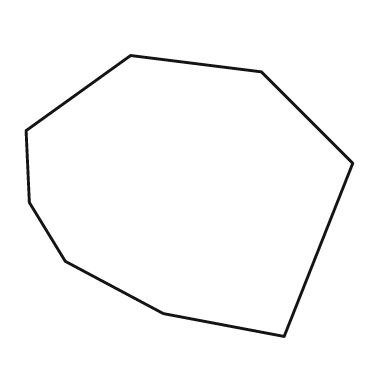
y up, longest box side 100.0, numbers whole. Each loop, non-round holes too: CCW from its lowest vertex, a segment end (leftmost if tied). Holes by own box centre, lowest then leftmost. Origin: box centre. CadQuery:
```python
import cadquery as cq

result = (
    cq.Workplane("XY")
    .moveTo(29.0, -43.0)
    .lineTo(50.0, 10.0)
    .lineTo(22.0, 38.0)
    .lineTo(-18.0, 43.0)
    .lineTo(-50.0, 20.0)
    .lineTo(-49.0, -2.0)
    .lineTo(-38.0, -20.0)
    .lineTo(-8.0, -36.0)
    .close()
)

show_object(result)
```